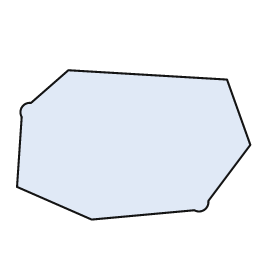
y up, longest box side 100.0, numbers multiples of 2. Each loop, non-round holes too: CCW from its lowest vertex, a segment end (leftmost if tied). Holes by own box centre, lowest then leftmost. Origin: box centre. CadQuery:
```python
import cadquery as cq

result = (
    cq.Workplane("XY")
    .moveTo(-18.0, -32.0)
    .lineTo(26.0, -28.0)
    .threePointArc((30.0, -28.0), (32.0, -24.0))
    .lineTo(50.0, 0.0)
    .lineTo(40.0, 28.0)
    .lineTo(-28.0, 32.0)
    .lineTo(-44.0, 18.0)
    .threePointArc((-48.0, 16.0), (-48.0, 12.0))
    .lineTo(-50.0, -18.0)
    .close()
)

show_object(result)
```